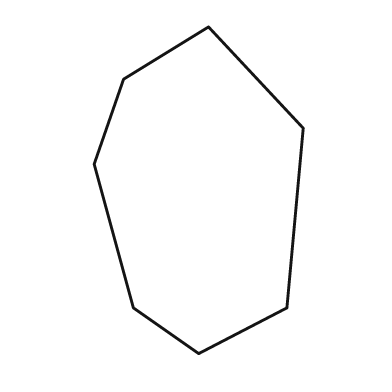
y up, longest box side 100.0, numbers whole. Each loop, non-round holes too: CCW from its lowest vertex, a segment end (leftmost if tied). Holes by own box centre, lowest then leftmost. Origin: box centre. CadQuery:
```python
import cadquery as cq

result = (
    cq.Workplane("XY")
    .moveTo(0.0, -50.0)
    .lineTo(27.0, -36.0)
    .lineTo(32.0, 19.0)
    .lineTo(3.0, 50.0)
    .lineTo(-23.0, 34.0)
    .lineTo(-32.0, 8.0)
    .lineTo(-20.0, -36.0)
    .close()
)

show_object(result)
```